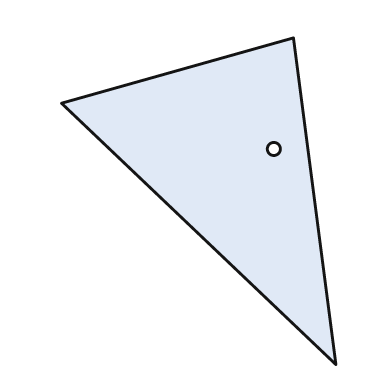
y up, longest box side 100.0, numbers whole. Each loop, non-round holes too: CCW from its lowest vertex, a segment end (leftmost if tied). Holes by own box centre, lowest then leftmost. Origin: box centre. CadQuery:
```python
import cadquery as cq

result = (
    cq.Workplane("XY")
    .moveTo(42.0, -50.0)
    .lineTo(29.0, 50.0)
    .lineTo(-42.0, 30.0)
    .close()
    .moveTo(23.0, 16.0)
    .circle(2.0)
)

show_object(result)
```